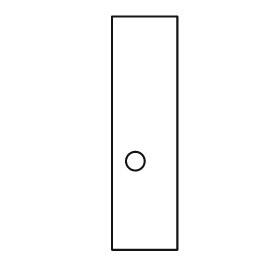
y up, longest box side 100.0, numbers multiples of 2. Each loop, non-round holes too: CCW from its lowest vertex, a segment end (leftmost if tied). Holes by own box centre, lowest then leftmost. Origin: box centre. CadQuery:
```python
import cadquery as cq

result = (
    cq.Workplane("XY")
    .moveTo(-14.0, -50.0)
    .lineTo(14.0, -50.0)
    .lineTo(14.0, 50.0)
    .lineTo(-14.0, 50.0)
    .close()
    .moveTo(-4.0, -12.0)
    .circle(4.0)
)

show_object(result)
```